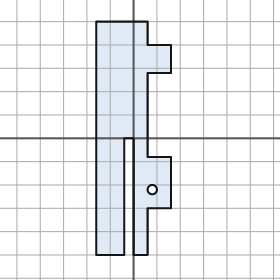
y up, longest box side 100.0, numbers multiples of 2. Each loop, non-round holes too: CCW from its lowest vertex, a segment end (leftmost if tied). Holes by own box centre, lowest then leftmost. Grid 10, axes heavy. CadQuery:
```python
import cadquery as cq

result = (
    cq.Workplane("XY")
    .moveTo(-16.0, -50.0)
    .lineTo(-4.0, -50.0)
    .lineTo(-4.0, 0.0)
    .lineTo(0.0, 0.0)
    .lineTo(0.0, -50.0)
    .lineTo(6.0, -50.0)
    .lineTo(6.0, -30.0)
    .lineTo(16.0, -30.0)
    .lineTo(16.0, -8.0)
    .lineTo(6.0, -8.0)
    .lineTo(6.0, 28.0)
    .lineTo(16.0, 28.0)
    .lineTo(16.0, 40.0)
    .lineTo(6.0, 40.0)
    .lineTo(6.0, 50.0)
    .lineTo(-16.0, 50.0)
    .close()
    .moveTo(8.0, -22.0)
    .circle(2.0)
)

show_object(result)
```